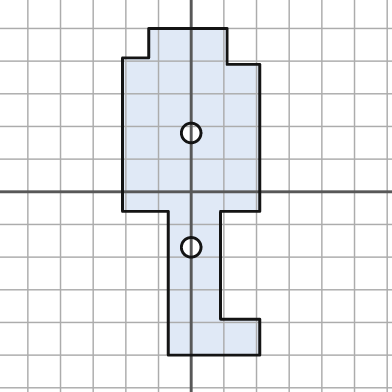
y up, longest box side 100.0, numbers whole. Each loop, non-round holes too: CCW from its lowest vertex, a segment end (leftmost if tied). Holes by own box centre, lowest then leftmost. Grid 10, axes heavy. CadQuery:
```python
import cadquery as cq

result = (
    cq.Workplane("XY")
    .moveTo(-7.0, -50.0)
    .lineTo(21.0, -50.0)
    .lineTo(21.0, -39.0)
    .lineTo(9.0, -39.0)
    .lineTo(9.0, -6.0)
    .lineTo(21.0, -6.0)
    .lineTo(21.0, 39.0)
    .lineTo(11.0, 39.0)
    .lineTo(11.0, 50.0)
    .lineTo(-13.0, 50.0)
    .lineTo(-13.0, 41.0)
    .lineTo(-21.0, 41.0)
    .lineTo(-21.0, -6.0)
    .lineTo(-7.0, -6.0)
    .close()
    .moveTo(0.0, -17.0)
    .circle(3.0)
    .moveTo(0.0, 18.0)
    .circle(3.0)
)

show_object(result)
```